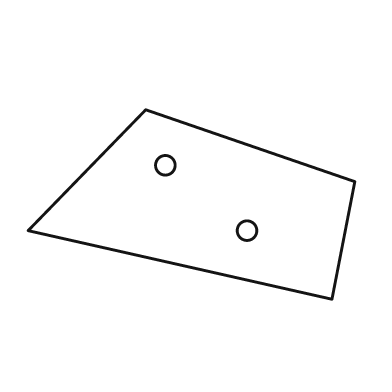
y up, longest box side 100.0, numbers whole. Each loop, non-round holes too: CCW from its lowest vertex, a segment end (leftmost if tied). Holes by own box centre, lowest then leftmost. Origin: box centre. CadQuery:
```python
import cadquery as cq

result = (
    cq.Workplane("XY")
    .moveTo(43.0, -29.0)
    .lineTo(50.0, 7.0)
    .lineTo(-14.0, 29.0)
    .lineTo(-50.0, -8.0)
    .close()
    .moveTo(17.0, -8.0)
    .circle(3.0)
    .moveTo(-8.0, 12.0)
    .circle(3.0)
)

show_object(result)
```